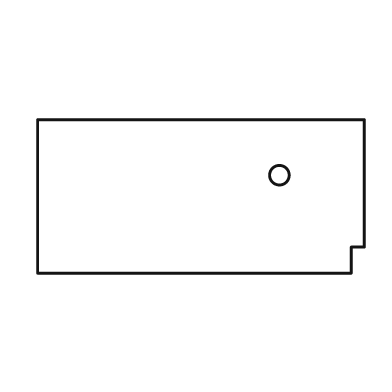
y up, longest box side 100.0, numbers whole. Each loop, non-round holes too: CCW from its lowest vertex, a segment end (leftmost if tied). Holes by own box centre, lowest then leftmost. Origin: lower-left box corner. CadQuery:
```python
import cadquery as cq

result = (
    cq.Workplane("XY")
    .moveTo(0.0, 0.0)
    .lineTo(96.0, 0.0)
    .lineTo(96.0, 8.0)
    .lineTo(100.0, 8.0)
    .lineTo(100.0, 47.0)
    .lineTo(0.0, 47.0)
    .close()
    .moveTo(74.0, 30.0)
    .circle(3.0)
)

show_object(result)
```